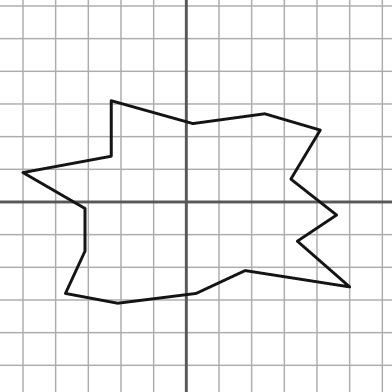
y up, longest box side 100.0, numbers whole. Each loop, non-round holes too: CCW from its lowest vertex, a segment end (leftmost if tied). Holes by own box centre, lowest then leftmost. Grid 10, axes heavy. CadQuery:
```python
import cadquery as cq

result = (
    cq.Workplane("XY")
    .moveTo(-21.0, -31.0)
    .lineTo(3.0, -28.0)
    .lineTo(18.0, -21.0)
    .lineTo(50.0, -26.0)
    .lineTo(34.0, -12.0)
    .lineTo(46.0, -4.0)
    .lineTo(32.0, 7.0)
    .lineTo(41.0, 22.0)
    .lineTo(24.0, 27.0)
    .lineTo(2.0, 24.0)
    .lineTo(-23.0, 31.0)
    .lineTo(-23.0, 14.0)
    .lineTo(-50.0, 9.0)
    .lineTo(-31.0, -2.0)
    .lineTo(-31.0, -15.0)
    .lineTo(-37.0, -28.0)
    .close()
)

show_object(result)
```